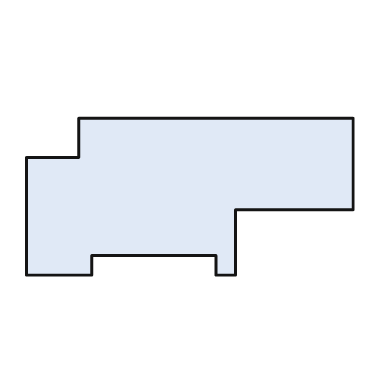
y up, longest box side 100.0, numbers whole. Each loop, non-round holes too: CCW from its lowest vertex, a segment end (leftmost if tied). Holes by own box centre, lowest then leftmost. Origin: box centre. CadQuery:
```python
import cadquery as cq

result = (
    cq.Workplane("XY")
    .moveTo(-50.0, -24.0)
    .lineTo(-30.0, -24.0)
    .lineTo(-30.0, -18.0)
    .lineTo(8.0, -18.0)
    .lineTo(8.0, -24.0)
    .lineTo(14.0, -24.0)
    .lineTo(14.0, -4.0)
    .lineTo(50.0, -4.0)
    .lineTo(50.0, 24.0)
    .lineTo(-34.0, 24.0)
    .lineTo(-34.0, 12.0)
    .lineTo(-50.0, 12.0)
    .close()
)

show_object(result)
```